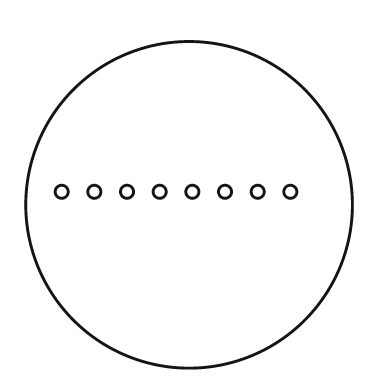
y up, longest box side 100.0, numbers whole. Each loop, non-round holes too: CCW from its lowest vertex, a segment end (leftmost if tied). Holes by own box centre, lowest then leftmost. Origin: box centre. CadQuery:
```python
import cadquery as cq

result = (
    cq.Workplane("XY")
    .moveTo(0.0, 0.0)
    .circle(50.0)
    .moveTo(-39.0, 4.0)
    .circle(2.0)
    .moveTo(-29.0, 4.0)
    .circle(2.0)
    .moveTo(-19.0, 4.0)
    .circle(2.0)
    .moveTo(-9.0, 4.0)
    .circle(2.0)
    .moveTo(1.0, 4.0)
    .circle(2.0)
    .moveTo(11.0, 4.0)
    .circle(2.0)
    .moveTo(21.0, 4.0)
    .circle(2.0)
    .moveTo(31.0, 4.0)
    .circle(2.0)
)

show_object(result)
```